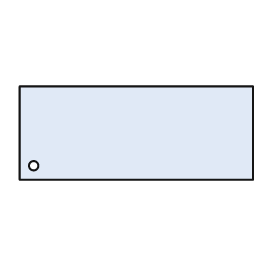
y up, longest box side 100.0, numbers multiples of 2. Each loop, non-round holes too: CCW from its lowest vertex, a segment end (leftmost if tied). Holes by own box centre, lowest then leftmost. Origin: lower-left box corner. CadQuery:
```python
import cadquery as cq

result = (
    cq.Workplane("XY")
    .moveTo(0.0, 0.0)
    .lineTo(100.0, 0.0)
    .lineTo(100.0, 40.0)
    .lineTo(0.0, 40.0)
    .close()
    .moveTo(6.0, 6.0)
    .circle(2.0)
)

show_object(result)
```